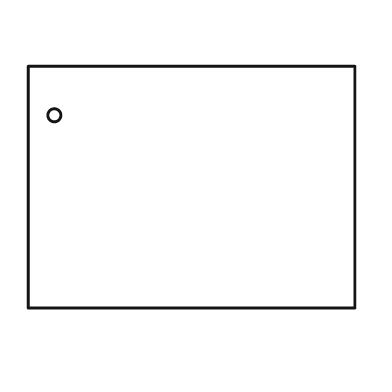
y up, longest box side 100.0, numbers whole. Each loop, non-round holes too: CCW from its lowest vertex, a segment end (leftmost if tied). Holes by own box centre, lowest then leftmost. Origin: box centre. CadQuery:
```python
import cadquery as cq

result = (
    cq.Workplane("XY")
    .moveTo(-50.0, -37.0)
    .lineTo(50.0, -37.0)
    .lineTo(50.0, 37.0)
    .lineTo(-50.0, 37.0)
    .close()
    .moveTo(-42.0, 22.0)
    .circle(2.0)
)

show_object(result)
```